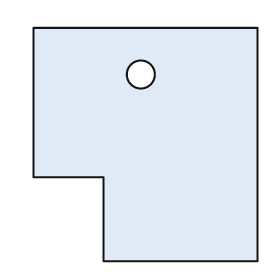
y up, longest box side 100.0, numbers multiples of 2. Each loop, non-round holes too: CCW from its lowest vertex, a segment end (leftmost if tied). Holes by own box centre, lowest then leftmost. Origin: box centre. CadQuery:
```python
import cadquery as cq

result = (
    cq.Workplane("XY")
    .moveTo(-18.0, -50.0)
    .lineTo(48.0, -50.0)
    .lineTo(48.0, 50.0)
    .lineTo(-48.0, 50.0)
    .lineTo(-48.0, -14.0)
    .lineTo(-18.0, -14.0)
    .close()
    .moveTo(-2.0, 30.0)
    .circle(6.0)
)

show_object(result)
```